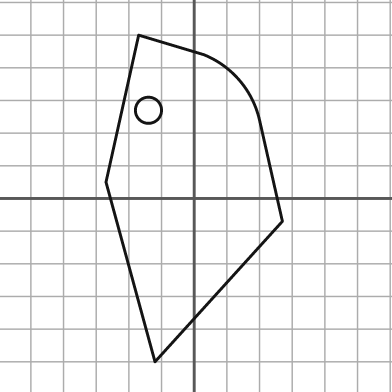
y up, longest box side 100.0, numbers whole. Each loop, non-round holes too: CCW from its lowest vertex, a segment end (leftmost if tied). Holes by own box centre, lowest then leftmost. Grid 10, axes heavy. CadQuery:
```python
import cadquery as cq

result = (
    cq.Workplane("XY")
    .moveTo(-12.0, -50.0)
    .lineTo(27.0, -7.0)
    .lineTo(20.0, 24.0)
    .threePointArc((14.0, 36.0), (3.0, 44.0))
    .lineTo(-17.0, 50.0)
    .lineTo(-27.0, 5.0)
    .close()
    .moveTo(-14.0, 27.0)
    .circle(4.0)
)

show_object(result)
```